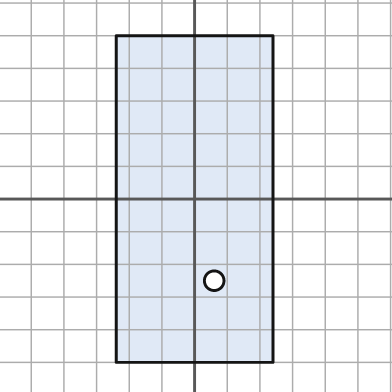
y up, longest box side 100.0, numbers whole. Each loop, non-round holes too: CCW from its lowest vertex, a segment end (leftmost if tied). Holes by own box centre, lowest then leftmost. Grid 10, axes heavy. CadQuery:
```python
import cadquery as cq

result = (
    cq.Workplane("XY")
    .moveTo(-24.0, -50.0)
    .lineTo(24.0, -50.0)
    .lineTo(24.0, 50.0)
    .lineTo(-24.0, 50.0)
    .close()
    .moveTo(6.0, -25.0)
    .circle(3.0)
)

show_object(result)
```